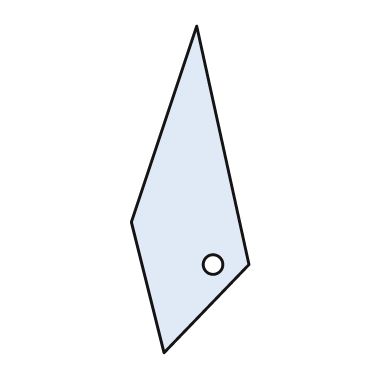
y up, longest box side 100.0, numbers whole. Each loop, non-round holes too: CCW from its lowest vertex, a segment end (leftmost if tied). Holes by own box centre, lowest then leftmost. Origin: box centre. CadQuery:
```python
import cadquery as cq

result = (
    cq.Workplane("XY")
    .moveTo(-8.0, -50.0)
    .lineTo(18.0, -23.0)
    .lineTo(2.0, 50.0)
    .lineTo(-18.0, -10.0)
    .close()
    .moveTo(7.0, -23.0)
    .circle(3.0)
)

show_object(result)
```